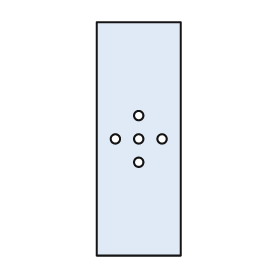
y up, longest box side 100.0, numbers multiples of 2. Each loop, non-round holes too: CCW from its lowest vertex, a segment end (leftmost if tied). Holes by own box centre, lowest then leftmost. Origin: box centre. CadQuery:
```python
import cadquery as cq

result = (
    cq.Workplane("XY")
    .moveTo(-18.0, -50.0)
    .lineTo(18.0, -50.0)
    .lineTo(18.0, 50.0)
    .lineTo(-18.0, 50.0)
    .close()
    .moveTo(0.0, -10.0)
    .circle(2.0)
    .moveTo(-10.0, 0.0)
    .circle(2.0)
    .moveTo(0.0, 0.0)
    .circle(2.0)
    .moveTo(10.0, 0.0)
    .circle(2.0)
    .moveTo(0.0, 10.0)
    .circle(2.0)
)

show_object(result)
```